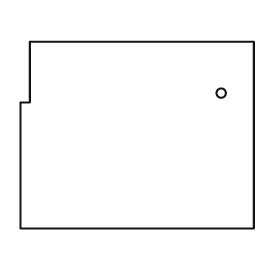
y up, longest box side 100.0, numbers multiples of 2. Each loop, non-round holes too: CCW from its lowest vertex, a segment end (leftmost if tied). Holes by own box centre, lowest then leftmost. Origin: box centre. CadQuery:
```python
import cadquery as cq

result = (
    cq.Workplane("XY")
    .moveTo(-50.0, -40.0)
    .lineTo(50.0, -40.0)
    .lineTo(50.0, 40.0)
    .lineTo(-46.0, 40.0)
    .lineTo(-46.0, 14.0)
    .lineTo(-50.0, 14.0)
    .close()
    .moveTo(36.0, 18.0)
    .circle(2.0)
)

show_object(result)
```